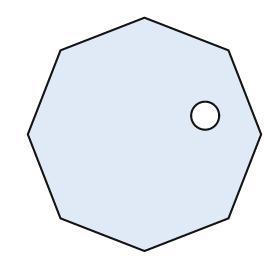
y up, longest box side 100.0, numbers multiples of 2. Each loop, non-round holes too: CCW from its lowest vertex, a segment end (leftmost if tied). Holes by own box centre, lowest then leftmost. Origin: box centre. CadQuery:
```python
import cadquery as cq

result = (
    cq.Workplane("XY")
    .moveTo(0.0, -50.0)
    .lineTo(36.0, -36.0)
    .lineTo(50.0, 0.0)
    .lineTo(36.0, 36.0)
    .lineTo(0.0, 50.0)
    .lineTo(-36.0, 36.0)
    .lineTo(-50.0, 0.0)
    .lineTo(-36.0, -36.0)
    .close()
    .moveTo(26.0, 8.0)
    .circle(6.0)
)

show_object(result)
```